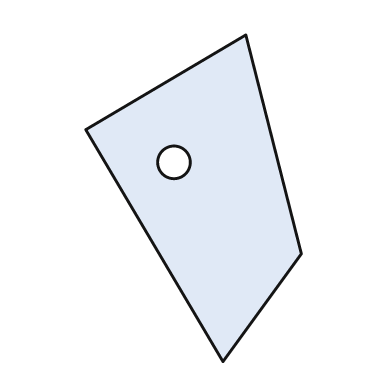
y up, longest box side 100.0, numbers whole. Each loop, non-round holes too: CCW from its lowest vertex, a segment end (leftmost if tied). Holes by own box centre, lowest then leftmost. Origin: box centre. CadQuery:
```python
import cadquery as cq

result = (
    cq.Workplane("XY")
    .moveTo(9.0, -50.0)
    .lineTo(33.0, -17.0)
    .lineTo(16.0, 50.0)
    .lineTo(-33.0, 21.0)
    .close()
    .moveTo(-6.0, 11.0)
    .circle(5.0)
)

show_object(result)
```